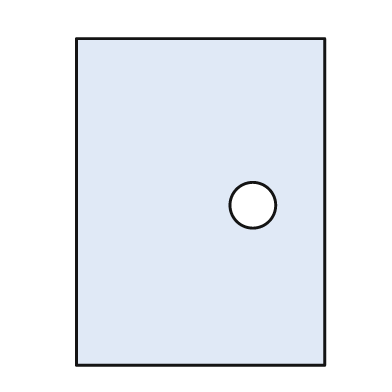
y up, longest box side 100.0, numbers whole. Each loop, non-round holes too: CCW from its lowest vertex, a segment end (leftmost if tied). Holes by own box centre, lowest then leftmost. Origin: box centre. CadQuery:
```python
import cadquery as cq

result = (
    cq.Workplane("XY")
    .moveTo(-38.0, -50.0)
    .lineTo(38.0, -50.0)
    .lineTo(38.0, 50.0)
    .lineTo(-38.0, 50.0)
    .close()
    .moveTo(16.0, -1.0)
    .circle(7.0)
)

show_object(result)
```